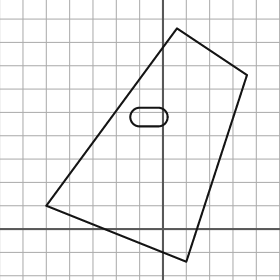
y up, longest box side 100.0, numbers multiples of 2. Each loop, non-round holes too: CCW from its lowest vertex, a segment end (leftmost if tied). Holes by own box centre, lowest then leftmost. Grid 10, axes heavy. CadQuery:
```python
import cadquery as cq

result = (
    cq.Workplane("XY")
    .moveTo(10.0, -14.0)
    .lineTo(36.0, 66.0)
    .lineTo(6.0, 86.0)
    .lineTo(-50.0, 10.0)
    .close()
    .moveTo(-10.0, 44.0)
    .lineTo(-2.0, 44.0)
    .threePointArc((2.0, 48.0), (-2.0, 52.0))
    .lineTo(-10.0, 52.0)
    .threePointArc((-14.0, 48.0), (-10.0, 44.0))
    .close()
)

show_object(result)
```